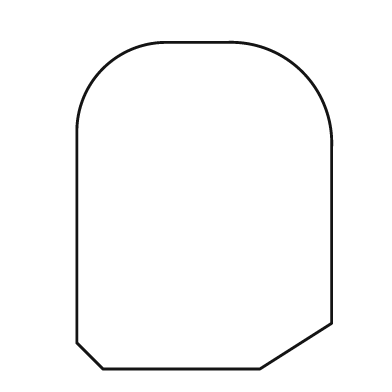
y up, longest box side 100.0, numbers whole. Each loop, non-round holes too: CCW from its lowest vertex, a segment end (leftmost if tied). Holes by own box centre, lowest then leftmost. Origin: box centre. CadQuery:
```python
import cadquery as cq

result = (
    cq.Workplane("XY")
    .moveTo(-31.0, -50.0)
    .lineTo(17.0, -50.0)
    .lineTo(39.0, -36.0)
    .lineTo(39.0, 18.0)
    .threePointArc((30.0, 41.0), (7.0, 50.0))
    .lineTo(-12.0, 50.0)
    .threePointArc((-31.0, 42.0), (-39.0, 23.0))
    .lineTo(-39.0, -42.0)
    .close()
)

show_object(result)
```